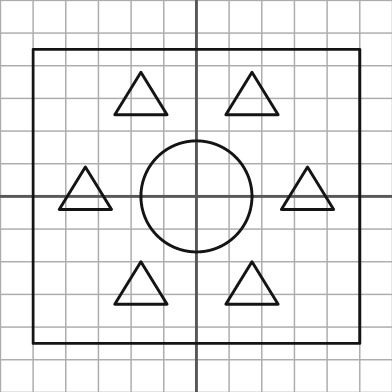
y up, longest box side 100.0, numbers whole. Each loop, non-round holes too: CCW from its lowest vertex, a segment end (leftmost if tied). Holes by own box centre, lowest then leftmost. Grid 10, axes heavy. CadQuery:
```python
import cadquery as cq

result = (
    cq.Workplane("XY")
    .moveTo(-50.0, -45.0)
    .lineTo(50.0, -45.0)
    .lineTo(50.0, 45.0)
    .lineTo(-50.0, 45.0)
    .close()
    .moveTo(-25.0, -33.0)
    .lineTo(-9.0, -33.0)
    .lineTo(-17.0, -20.0)
    .close()
    .moveTo(9.0, -33.0)
    .lineTo(25.0, -33.0)
    .lineTo(17.0, -20.0)
    .close()
    .moveTo(0.0, 0.0)
    .circle(17.0)
    .moveTo(-42.0, -4.0)
    .lineTo(-26.0, -4.0)
    .lineTo(-34.0, 9.0)
    .close()
    .moveTo(26.0, -4.0)
    .lineTo(42.0, -4.0)
    .lineTo(34.0, 9.0)
    .close()
    .moveTo(-25.0, 25.0)
    .lineTo(-9.0, 25.0)
    .lineTo(-17.0, 38.0)
    .close()
    .moveTo(9.0, 25.0)
    .lineTo(25.0, 25.0)
    .lineTo(17.0, 38.0)
    .close()
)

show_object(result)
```